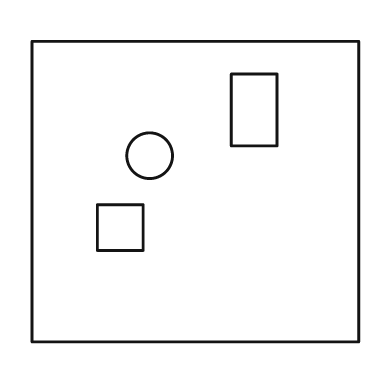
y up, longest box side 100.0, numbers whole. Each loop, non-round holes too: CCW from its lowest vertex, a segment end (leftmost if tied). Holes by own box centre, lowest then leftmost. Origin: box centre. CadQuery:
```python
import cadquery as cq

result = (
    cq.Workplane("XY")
    .moveTo(-50.0, -46.0)
    .lineTo(50.0, -46.0)
    .lineTo(50.0, 46.0)
    .lineTo(-50.0, 46.0)
    .close()
    .moveTo(-30.0, -18.0)
    .lineTo(-16.0, -18.0)
    .lineTo(-16.0, -4.0)
    .lineTo(-30.0, -4.0)
    .close()
    .moveTo(-14.0, 11.0)
    .circle(7.0)
    .moveTo(11.0, 14.0)
    .lineTo(25.0, 14.0)
    .lineTo(25.0, 36.0)
    .lineTo(11.0, 36.0)
    .close()
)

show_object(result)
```